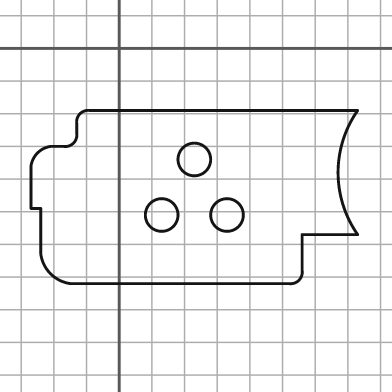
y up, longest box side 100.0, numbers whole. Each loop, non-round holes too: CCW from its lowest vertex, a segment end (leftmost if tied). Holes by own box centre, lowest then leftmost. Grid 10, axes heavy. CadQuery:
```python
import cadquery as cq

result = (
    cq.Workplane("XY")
    .moveTo(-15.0, -72.0)
    .lineTo(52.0, -72.0)
    .threePointArc((55.0, -71.0), (56.0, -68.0))
    .lineTo(56.0, -57.0)
    .lineTo(73.0, -57.0)
    .threePointArc((67.0, -38.0), (73.0, -19.0))
    .lineTo(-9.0, -19.0)
    .threePointArc((-12.0, -20.0), (-13.0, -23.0))
    .lineTo(-13.0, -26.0)
    .threePointArc((-14.0, -29.0), (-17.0, -30.0))
    .lineTo(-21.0, -30.0)
    .threePointArc((-25.0, -32.0), (-27.0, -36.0))
    .lineTo(-27.0, -49.0)
    .lineTo(-24.0, -49.0)
    .lineTo(-24.0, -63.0)
    .threePointArc((-21.0, -69.0), (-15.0, -72.0))
    .close()
    .moveTo(13.0, -51.0)
    .circle(5.0)
    .moveTo(33.0, -51.0)
    .circle(5.0)
    .moveTo(23.0, -34.0)
    .circle(5.0)
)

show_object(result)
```